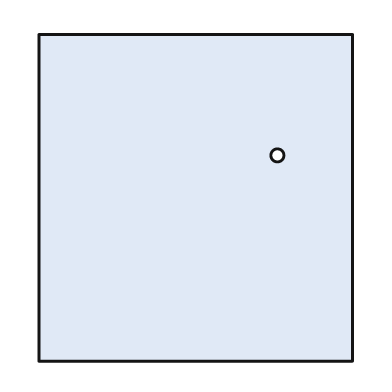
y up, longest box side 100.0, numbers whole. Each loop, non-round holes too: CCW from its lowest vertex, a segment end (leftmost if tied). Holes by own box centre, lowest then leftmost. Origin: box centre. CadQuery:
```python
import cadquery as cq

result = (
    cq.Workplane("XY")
    .moveTo(-48.0, -50.0)
    .lineTo(48.0, -50.0)
    .lineTo(48.0, 50.0)
    .lineTo(-48.0, 50.0)
    .close()
    .moveTo(25.0, 13.0)
    .circle(2.0)
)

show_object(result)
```